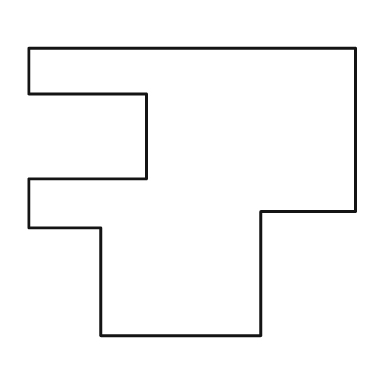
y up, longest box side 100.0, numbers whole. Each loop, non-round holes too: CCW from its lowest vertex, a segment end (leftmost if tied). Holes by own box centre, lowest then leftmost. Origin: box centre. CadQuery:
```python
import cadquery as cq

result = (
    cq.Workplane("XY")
    .moveTo(-28.0, -44.0)
    .lineTo(21.0, -44.0)
    .lineTo(21.0, -6.0)
    .lineTo(50.0, -6.0)
    .lineTo(50.0, 44.0)
    .lineTo(-50.0, 44.0)
    .lineTo(-50.0, 30.0)
    .lineTo(-14.0, 30.0)
    .lineTo(-14.0, 4.0)
    .lineTo(-50.0, 4.0)
    .lineTo(-50.0, -11.0)
    .lineTo(-28.0, -11.0)
    .close()
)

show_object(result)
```